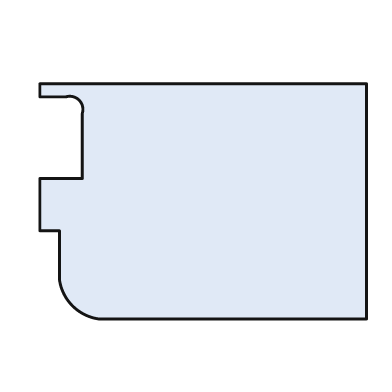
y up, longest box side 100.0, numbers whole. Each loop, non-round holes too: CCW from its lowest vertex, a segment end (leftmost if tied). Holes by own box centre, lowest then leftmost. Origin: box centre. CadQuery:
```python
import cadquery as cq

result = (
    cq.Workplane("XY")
    .moveTo(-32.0, -36.0)
    .lineTo(50.0, -36.0)
    .lineTo(50.0, 36.0)
    .lineTo(-50.0, 36.0)
    .lineTo(-50.0, 32.0)
    .lineTo(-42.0, 32.0)
    .threePointArc((-38.0, 31.0), (-37.0, 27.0))
    .lineTo(-37.0, 7.0)
    .lineTo(-50.0, 7.0)
    .lineTo(-50.0, -9.0)
    .lineTo(-44.0, -9.0)
    .lineTo(-44.0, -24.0)
    .threePointArc((-40.0, -32.0), (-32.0, -36.0))
    .close()
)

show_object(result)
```